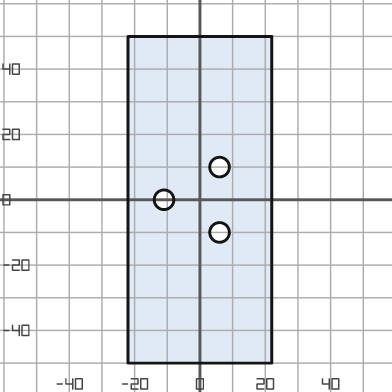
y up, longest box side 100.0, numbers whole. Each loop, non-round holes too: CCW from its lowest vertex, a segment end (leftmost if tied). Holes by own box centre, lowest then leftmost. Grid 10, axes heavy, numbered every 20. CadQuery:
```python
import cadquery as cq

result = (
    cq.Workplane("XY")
    .moveTo(-22.0, -50.0)
    .lineTo(22.0, -50.0)
    .lineTo(22.0, 50.0)
    .lineTo(-22.0, 50.0)
    .close()
    .moveTo(6.0, -10.0)
    .circle(3.0)
    .moveTo(-11.0, 0.0)
    .circle(3.0)
    .moveTo(6.0, 10.0)
    .circle(3.0)
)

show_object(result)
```